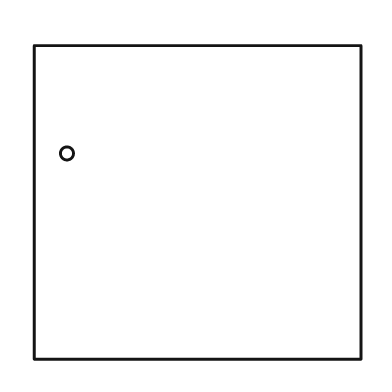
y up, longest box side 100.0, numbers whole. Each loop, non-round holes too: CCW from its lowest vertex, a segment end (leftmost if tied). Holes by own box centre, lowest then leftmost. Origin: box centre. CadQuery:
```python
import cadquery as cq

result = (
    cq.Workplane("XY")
    .moveTo(-50.0, -48.0)
    .lineTo(50.0, -48.0)
    .lineTo(50.0, 48.0)
    .lineTo(-50.0, 48.0)
    .close()
    .moveTo(-40.0, 15.0)
    .circle(2.0)
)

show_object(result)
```